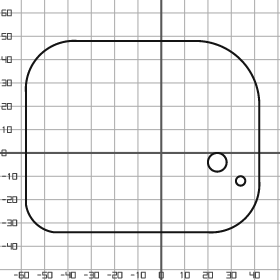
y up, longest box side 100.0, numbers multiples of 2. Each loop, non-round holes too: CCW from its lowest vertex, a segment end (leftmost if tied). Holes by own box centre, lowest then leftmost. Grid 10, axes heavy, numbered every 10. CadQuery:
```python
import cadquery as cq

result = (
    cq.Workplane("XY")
    .moveTo(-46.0, -34.0)
    .lineTo(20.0, -34.0)
    .threePointArc((36.0, -28.0), (42.0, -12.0))
    .lineTo(42.0, 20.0)
    .threePointArc((34.0, 40.0), (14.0, 48.0))
    .lineTo(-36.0, 48.0)
    .threePointArc((-52.0, 42.0), (-58.0, 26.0))
    .lineTo(-58.0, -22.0)
    .threePointArc((-54.0, -30.0), (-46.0, -34.0))
    .close()
    .moveTo(34.0, -12.0)
    .circle(2.0)
    .moveTo(24.0, -4.0)
    .circle(4.0)
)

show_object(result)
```